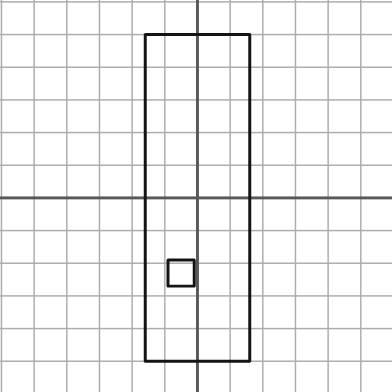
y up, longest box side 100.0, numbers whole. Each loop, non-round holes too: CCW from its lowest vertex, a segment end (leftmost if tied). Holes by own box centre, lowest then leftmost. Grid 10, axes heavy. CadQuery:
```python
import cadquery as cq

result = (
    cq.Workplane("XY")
    .moveTo(-16.0, -50.0)
    .lineTo(16.0, -50.0)
    .lineTo(16.0, 50.0)
    .lineTo(-16.0, 50.0)
    .close()
    .moveTo(-9.0, -27.0)
    .lineTo(-1.0, -27.0)
    .lineTo(-1.0, -19.0)
    .lineTo(-9.0, -19.0)
    .close()
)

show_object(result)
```